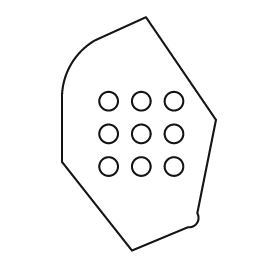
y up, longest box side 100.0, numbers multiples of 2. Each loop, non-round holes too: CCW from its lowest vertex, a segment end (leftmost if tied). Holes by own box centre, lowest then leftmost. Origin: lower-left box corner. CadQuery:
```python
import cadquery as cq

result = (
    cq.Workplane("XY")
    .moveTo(30.0, 0.0)
    .lineTo(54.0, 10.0)
    .threePointArc((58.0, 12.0), (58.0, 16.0))
    .lineTo(66.0, 56.0)
    .lineTo(36.0, 100.0)
    .lineTo(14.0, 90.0)
    .threePointArc((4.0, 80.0), (0.0, 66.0))
    .lineTo(0.0, 38.0)
    .close()
    .moveTo(20.0, 36.0)
    .circle(4.0)
    .moveTo(34.0, 36.0)
    .circle(4.0)
    .moveTo(48.0, 36.0)
    .circle(4.0)
    .moveTo(20.0, 50.0)
    .circle(4.0)
    .moveTo(34.0, 50.0)
    .circle(4.0)
    .moveTo(48.0, 50.0)
    .circle(4.0)
    .moveTo(20.0, 64.0)
    .circle(4.0)
    .moveTo(34.0, 64.0)
    .circle(4.0)
    .moveTo(48.0, 64.0)
    .circle(4.0)
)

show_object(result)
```